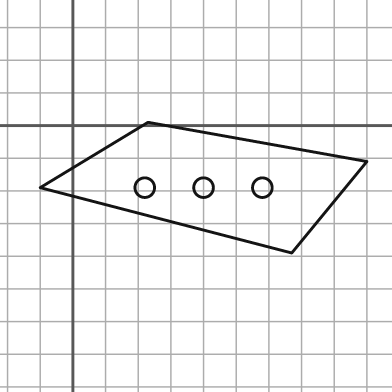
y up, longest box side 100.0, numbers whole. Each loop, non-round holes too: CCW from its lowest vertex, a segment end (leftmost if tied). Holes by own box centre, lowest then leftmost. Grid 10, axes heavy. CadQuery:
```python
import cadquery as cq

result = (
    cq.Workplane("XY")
    .moveTo(67.0, -39.0)
    .lineTo(90.0, -11.0)
    .lineTo(23.0, 1.0)
    .lineTo(-10.0, -19.0)
    .close()
    .moveTo(22.0, -19.0)
    .circle(3.0)
    .moveTo(40.0, -19.0)
    .circle(3.0)
    .moveTo(58.0, -19.0)
    .circle(3.0)
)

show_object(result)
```